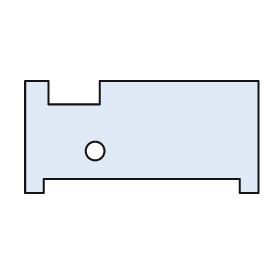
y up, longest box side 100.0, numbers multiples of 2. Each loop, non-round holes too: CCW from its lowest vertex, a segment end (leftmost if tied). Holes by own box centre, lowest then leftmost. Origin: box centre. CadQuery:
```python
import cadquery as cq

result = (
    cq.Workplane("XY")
    .moveTo(-50.0, -24.0)
    .lineTo(-42.0, -24.0)
    .lineTo(-42.0, -18.0)
    .lineTo(42.0, -18.0)
    .lineTo(42.0, -24.0)
    .lineTo(50.0, -24.0)
    .lineTo(50.0, 24.0)
    .lineTo(-18.0, 24.0)
    .lineTo(-18.0, 14.0)
    .lineTo(-40.0, 14.0)
    .lineTo(-40.0, 24.0)
    .lineTo(-50.0, 24.0)
    .close()
    .moveTo(-20.0, -6.0)
    .circle(4.0)
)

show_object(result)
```